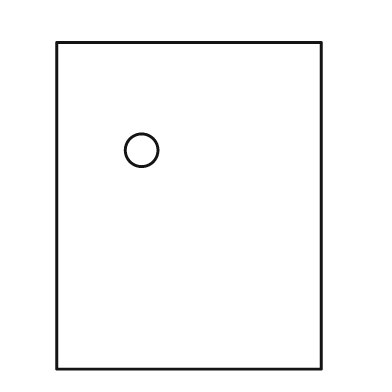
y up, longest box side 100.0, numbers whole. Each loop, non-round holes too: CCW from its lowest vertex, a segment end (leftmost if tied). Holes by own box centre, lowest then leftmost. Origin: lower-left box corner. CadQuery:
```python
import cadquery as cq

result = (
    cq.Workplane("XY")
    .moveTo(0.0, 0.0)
    .lineTo(81.0, 0.0)
    .lineTo(81.0, 100.0)
    .lineTo(0.0, 100.0)
    .close()
    .moveTo(26.0, 67.0)
    .circle(5.0)
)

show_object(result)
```